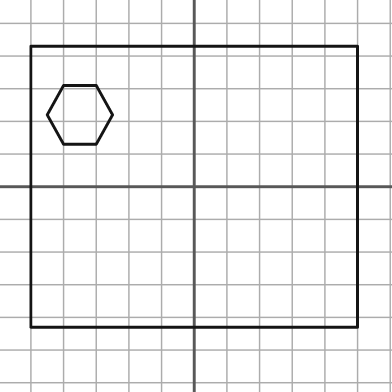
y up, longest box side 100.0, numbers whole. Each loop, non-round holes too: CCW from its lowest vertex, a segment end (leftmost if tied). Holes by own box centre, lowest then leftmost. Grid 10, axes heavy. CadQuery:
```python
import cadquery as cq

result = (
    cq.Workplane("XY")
    .moveTo(-50.0, -43.0)
    .lineTo(50.0, -43.0)
    .lineTo(50.0, 43.0)
    .lineTo(-50.0, 43.0)
    .close()
    .moveTo(-40.0, 13.0)
    .lineTo(-30.0, 13.0)
    .lineTo(-25.0, 22.0)
    .lineTo(-30.0, 31.0)
    .lineTo(-40.0, 31.0)
    .lineTo(-45.0, 22.0)
    .close()
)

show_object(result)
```